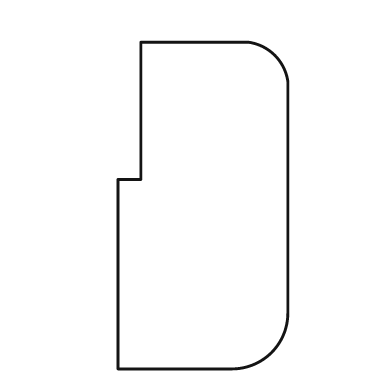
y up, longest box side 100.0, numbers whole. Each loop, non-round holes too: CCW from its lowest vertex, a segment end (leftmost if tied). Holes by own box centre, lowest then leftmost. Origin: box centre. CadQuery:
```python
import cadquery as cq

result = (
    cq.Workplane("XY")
    .moveTo(-26.0, -50.0)
    .lineTo(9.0, -50.0)
    .threePointArc((21.0, -45.0), (26.0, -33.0))
    .lineTo(26.0, 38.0)
    .threePointArc((22.0, 46.0), (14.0, 50.0))
    .lineTo(-19.0, 50.0)
    .lineTo(-19.0, 8.0)
    .lineTo(-26.0, 8.0)
    .close()
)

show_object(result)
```